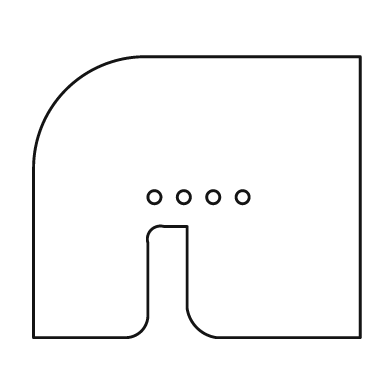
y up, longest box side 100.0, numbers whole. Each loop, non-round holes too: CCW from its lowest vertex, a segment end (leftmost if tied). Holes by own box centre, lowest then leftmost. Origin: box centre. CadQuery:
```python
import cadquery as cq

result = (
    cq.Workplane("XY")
    .moveTo(-50.0, -43.0)
    .lineTo(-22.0, -43.0)
    .threePointArc((-17.0, -41.0), (-15.0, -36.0))
    .lineTo(-15.0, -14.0)
    .threePointArc((-14.0, -10.0), (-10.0, -9.0))
    .lineTo(-3.0, -9.0)
    .lineTo(-3.0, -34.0)
    .threePointArc((0.0, -40.0), (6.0, -43.0))
    .lineTo(50.0, -43.0)
    .lineTo(50.0, 43.0)
    .lineTo(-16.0, 43.0)
    .threePointArc((-40.0, 33.0), (-50.0, 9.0))
    .close()
    .moveTo(-13.0, 0.0)
    .circle(2.0)
    .moveTo(-4.0, 0.0)
    .circle(2.0)
    .moveTo(5.0, 0.0)
    .circle(2.0)
    .moveTo(14.0, 0.0)
    .circle(2.0)
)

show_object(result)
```